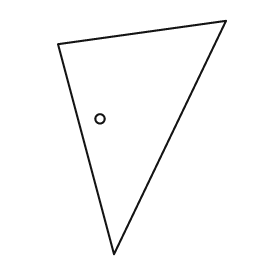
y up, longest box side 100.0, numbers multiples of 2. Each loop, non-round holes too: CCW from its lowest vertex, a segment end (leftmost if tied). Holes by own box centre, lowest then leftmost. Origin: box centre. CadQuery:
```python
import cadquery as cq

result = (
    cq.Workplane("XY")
    .moveTo(-12.0, -50.0)
    .lineTo(36.0, 50.0)
    .lineTo(-36.0, 40.0)
    .close()
    .moveTo(-18.0, 8.0)
    .circle(2.0)
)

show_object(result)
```